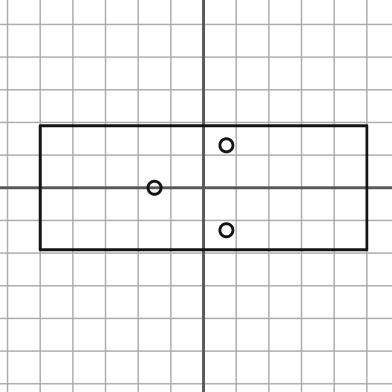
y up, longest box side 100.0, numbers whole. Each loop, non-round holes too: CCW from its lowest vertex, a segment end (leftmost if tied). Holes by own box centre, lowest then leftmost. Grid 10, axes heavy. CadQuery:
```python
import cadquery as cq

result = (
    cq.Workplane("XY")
    .moveTo(-50.0, -19.0)
    .lineTo(50.0, -19.0)
    .lineTo(50.0, 19.0)
    .lineTo(-50.0, 19.0)
    .close()
    .moveTo(7.0, -13.0)
    .circle(2.0)
    .moveTo(-15.0, 0.0)
    .circle(2.0)
    .moveTo(7.0, 13.0)
    .circle(2.0)
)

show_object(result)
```